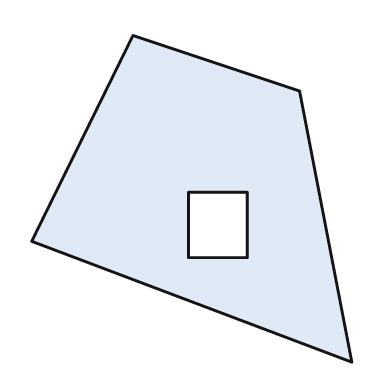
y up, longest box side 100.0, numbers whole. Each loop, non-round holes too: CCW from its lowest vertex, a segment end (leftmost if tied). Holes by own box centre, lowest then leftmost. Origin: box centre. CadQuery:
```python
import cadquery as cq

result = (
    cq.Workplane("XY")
    .moveTo(49.0, -50.0)
    .lineTo(33.0, 33.0)
    .lineTo(-18.0, 50.0)
    .lineTo(-49.0, -13.0)
    .close()
    .moveTo(-1.0, -18.0)
    .lineTo(17.0, -18.0)
    .lineTo(17.0, 2.0)
    .lineTo(-1.0, 2.0)
    .close()
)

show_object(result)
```